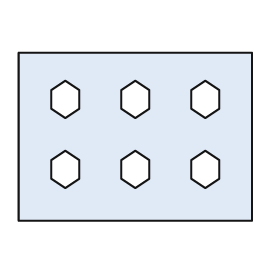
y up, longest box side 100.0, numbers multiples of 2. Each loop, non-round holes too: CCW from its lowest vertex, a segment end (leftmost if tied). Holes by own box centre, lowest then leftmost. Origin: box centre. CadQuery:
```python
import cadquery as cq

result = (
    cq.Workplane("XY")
    .moveTo(-50.0, -36.0)
    .lineTo(50.0, -36.0)
    .lineTo(50.0, 36.0)
    .lineTo(-50.0, 36.0)
    .close()
    .moveTo(-30.0, -22.0)
    .lineTo(-24.0, -18.0)
    .lineTo(-24.0, -10.0)
    .lineTo(-30.0, -6.0)
    .lineTo(-36.0, -10.0)
    .lineTo(-36.0, -18.0)
    .close()
    .moveTo(0.0, -22.0)
    .lineTo(6.0, -18.0)
    .lineTo(6.0, -10.0)
    .lineTo(0.0, -6.0)
    .lineTo(-6.0, -10.0)
    .lineTo(-6.0, -18.0)
    .close()
    .moveTo(30.0, -22.0)
    .lineTo(36.0, -18.0)
    .lineTo(36.0, -10.0)
    .lineTo(30.0, -6.0)
    .lineTo(24.0, -10.0)
    .lineTo(24.0, -18.0)
    .close()
    .moveTo(-30.0, 8.0)
    .lineTo(-24.0, 12.0)
    .lineTo(-24.0, 20.0)
    .lineTo(-30.0, 24.0)
    .lineTo(-36.0, 20.0)
    .lineTo(-36.0, 12.0)
    .close()
    .moveTo(0.0, 8.0)
    .lineTo(6.0, 12.0)
    .lineTo(6.0, 20.0)
    .lineTo(0.0, 24.0)
    .lineTo(-6.0, 20.0)
    .lineTo(-6.0, 12.0)
    .close()
    .moveTo(30.0, 8.0)
    .lineTo(36.0, 12.0)
    .lineTo(36.0, 20.0)
    .lineTo(30.0, 24.0)
    .lineTo(24.0, 20.0)
    .lineTo(24.0, 12.0)
    .close()
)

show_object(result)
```